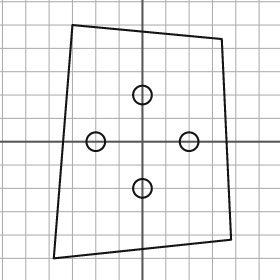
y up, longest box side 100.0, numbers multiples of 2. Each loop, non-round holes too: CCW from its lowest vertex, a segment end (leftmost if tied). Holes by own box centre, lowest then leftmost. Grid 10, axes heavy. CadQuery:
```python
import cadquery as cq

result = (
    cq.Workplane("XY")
    .moveTo(-38.0, -50.0)
    .lineTo(38.0, -42.0)
    .lineTo(34.0, 44.0)
    .lineTo(-30.0, 50.0)
    .close()
    .moveTo(0.0, -20.0)
    .circle(4.0)
    .moveTo(-20.0, 0.0)
    .circle(4.0)
    .moveTo(20.0, 0.0)
    .circle(4.0)
    .moveTo(0.0, 20.0)
    .circle(4.0)
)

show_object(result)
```